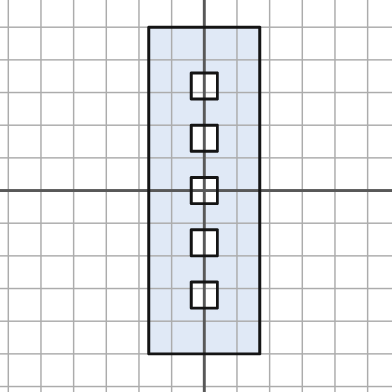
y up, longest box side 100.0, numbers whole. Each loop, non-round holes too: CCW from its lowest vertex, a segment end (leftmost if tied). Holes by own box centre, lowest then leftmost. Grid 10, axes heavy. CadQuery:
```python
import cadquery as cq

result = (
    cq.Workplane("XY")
    .moveTo(-17.0, -50.0)
    .lineTo(17.0, -50.0)
    .lineTo(17.0, 50.0)
    .lineTo(-17.0, 50.0)
    .close()
    .moveTo(-4.0, -36.0)
    .lineTo(4.0, -36.0)
    .lineTo(4.0, -28.0)
    .lineTo(-4.0, -28.0)
    .close()
    .moveTo(-4.0, -20.0)
    .lineTo(4.0, -20.0)
    .lineTo(4.0, -12.0)
    .lineTo(-4.0, -12.0)
    .close()
    .moveTo(-4.0, -4.0)
    .lineTo(4.0, -4.0)
    .lineTo(4.0, 4.0)
    .lineTo(-4.0, 4.0)
    .close()
    .moveTo(-4.0, 12.0)
    .lineTo(4.0, 12.0)
    .lineTo(4.0, 20.0)
    .lineTo(-4.0, 20.0)
    .close()
    .moveTo(-4.0, 28.0)
    .lineTo(4.0, 28.0)
    .lineTo(4.0, 36.0)
    .lineTo(-4.0, 36.0)
    .close()
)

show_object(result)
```